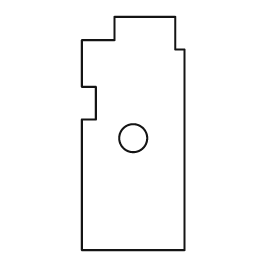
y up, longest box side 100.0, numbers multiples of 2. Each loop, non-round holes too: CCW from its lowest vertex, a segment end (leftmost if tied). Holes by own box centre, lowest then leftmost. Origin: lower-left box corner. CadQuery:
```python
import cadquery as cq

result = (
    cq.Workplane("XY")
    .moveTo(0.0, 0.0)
    .lineTo(44.0, 0.0)
    .lineTo(44.0, 86.0)
    .lineTo(40.0, 86.0)
    .lineTo(40.0, 100.0)
    .lineTo(14.0, 100.0)
    .lineTo(14.0, 90.0)
    .lineTo(0.0, 90.0)
    .lineTo(0.0, 70.0)
    .lineTo(6.0, 70.0)
    .lineTo(6.0, 56.0)
    .lineTo(0.0, 56.0)
    .close()
    .moveTo(22.0, 48.0)
    .circle(6.0)
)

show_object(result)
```